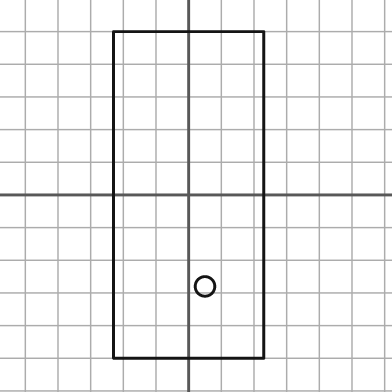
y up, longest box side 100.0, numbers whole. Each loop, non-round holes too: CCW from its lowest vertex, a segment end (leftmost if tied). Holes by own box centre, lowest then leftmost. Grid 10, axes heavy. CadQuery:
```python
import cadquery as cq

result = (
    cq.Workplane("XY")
    .moveTo(-23.0, -50.0)
    .lineTo(23.0, -50.0)
    .lineTo(23.0, 50.0)
    .lineTo(-23.0, 50.0)
    .close()
    .moveTo(5.0, -28.0)
    .circle(3.0)
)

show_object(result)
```